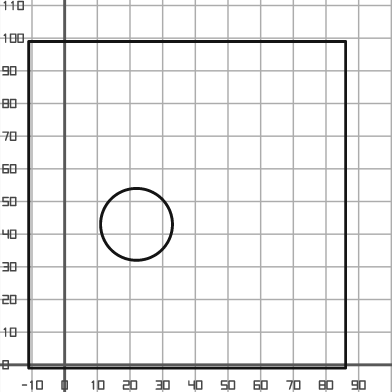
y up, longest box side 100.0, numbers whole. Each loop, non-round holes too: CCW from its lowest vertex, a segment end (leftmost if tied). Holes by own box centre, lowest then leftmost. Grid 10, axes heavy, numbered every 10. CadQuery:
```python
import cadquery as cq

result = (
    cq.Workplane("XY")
    .moveTo(-11.0, -1.0)
    .lineTo(86.0, -1.0)
    .lineTo(86.0, 99.0)
    .lineTo(-11.0, 99.0)
    .close()
    .moveTo(22.0, 43.0)
    .circle(11.0)
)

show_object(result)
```